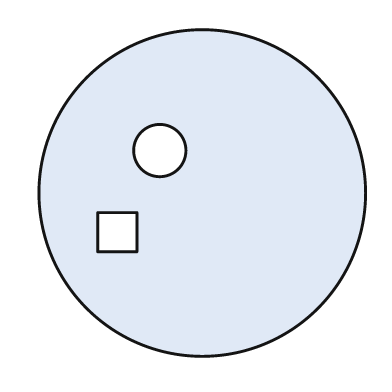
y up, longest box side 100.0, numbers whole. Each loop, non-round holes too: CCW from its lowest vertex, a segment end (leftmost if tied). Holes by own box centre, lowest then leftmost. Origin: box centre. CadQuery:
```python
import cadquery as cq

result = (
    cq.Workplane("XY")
    .moveTo(0.0, 0.0)
    .circle(50.0)
    .moveTo(-32.0, -18.0)
    .lineTo(-20.0, -18.0)
    .lineTo(-20.0, -6.0)
    .lineTo(-32.0, -6.0)
    .close()
    .moveTo(-13.0, 13.0)
    .circle(8.0)
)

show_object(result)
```